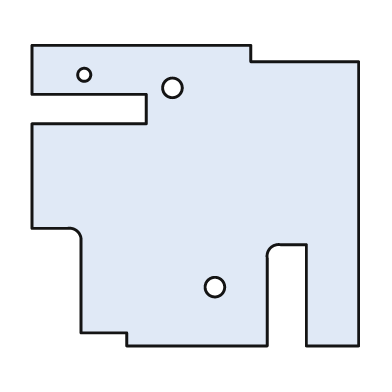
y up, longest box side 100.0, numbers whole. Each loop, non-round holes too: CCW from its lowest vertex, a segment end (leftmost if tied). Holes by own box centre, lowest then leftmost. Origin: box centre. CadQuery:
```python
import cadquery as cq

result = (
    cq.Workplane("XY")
    .moveTo(-21.0, -46.0)
    .lineTo(22.0, -46.0)
    .lineTo(22.0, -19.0)
    .threePointArc((23.0, -16.0), (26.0, -15.0))
    .lineTo(34.0, -15.0)
    .lineTo(34.0, -46.0)
    .lineTo(50.0, -46.0)
    .lineTo(50.0, 41.0)
    .lineTo(17.0, 41.0)
    .lineTo(17.0, 46.0)
    .lineTo(-50.0, 46.0)
    .lineTo(-50.0, 31.0)
    .lineTo(-15.0, 31.0)
    .lineTo(-15.0, 22.0)
    .lineTo(-50.0, 22.0)
    .lineTo(-50.0, -10.0)
    .lineTo(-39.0, -10.0)
    .threePointArc((-36.0, -11.0), (-35.0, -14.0))
    .lineTo(-35.0, -42.0)
    .lineTo(-21.0, -42.0)
    .close()
    .moveTo(6.0, -28.0)
    .circle(3.0)
    .moveTo(-7.0, 33.0)
    .circle(3.0)
    .moveTo(-34.0, 37.0)
    .circle(2.0)
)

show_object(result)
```